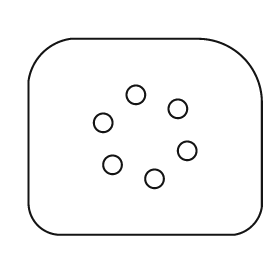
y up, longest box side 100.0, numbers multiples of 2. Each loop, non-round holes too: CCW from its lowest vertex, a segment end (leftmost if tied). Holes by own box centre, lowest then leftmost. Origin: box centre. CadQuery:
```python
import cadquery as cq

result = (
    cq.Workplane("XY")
    .moveTo(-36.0, -42.0)
    .lineTo(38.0, -42.0)
    .threePointArc((46.0, -38.0), (50.0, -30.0))
    .lineTo(50.0, 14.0)
    .threePointArc((42.0, 34.0), (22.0, 42.0))
    .lineTo(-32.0, 42.0)
    .threePointArc((-44.0, 36.0), (-50.0, 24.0))
    .lineTo(-50.0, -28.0)
    .threePointArc((-46.0, -38.0), (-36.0, -42.0))
    .close()
    .moveTo(4.0, -18.0)
    .circle(4.0)
    .moveTo(-14.0, -12.0)
    .circle(4.0)
    .moveTo(18.0, -6.0)
    .circle(4.0)
    .moveTo(-18.0, 6.0)
    .circle(4.0)
    .moveTo(14.0, 12.0)
    .circle(4.0)
    .moveTo(-4.0, 18.0)
    .circle(4.0)
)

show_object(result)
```